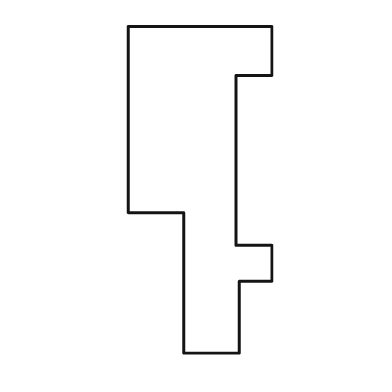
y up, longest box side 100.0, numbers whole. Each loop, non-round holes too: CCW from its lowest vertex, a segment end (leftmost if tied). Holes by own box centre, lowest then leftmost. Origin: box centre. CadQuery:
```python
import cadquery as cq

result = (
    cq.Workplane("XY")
    .moveTo(-5.0, -50.0)
    .lineTo(12.0, -50.0)
    .lineTo(12.0, -28.0)
    .lineTo(22.0, -28.0)
    .lineTo(22.0, -17.0)
    .lineTo(11.0, -17.0)
    .lineTo(11.0, 35.0)
    .lineTo(22.0, 35.0)
    .lineTo(22.0, 50.0)
    .lineTo(-22.0, 50.0)
    .lineTo(-22.0, -7.0)
    .lineTo(-5.0, -7.0)
    .close()
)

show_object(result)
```